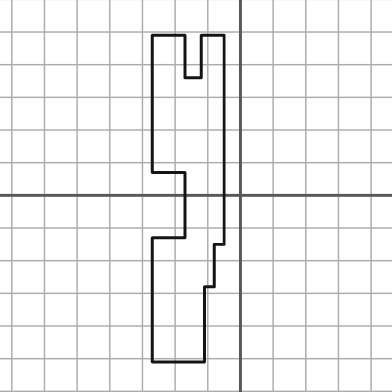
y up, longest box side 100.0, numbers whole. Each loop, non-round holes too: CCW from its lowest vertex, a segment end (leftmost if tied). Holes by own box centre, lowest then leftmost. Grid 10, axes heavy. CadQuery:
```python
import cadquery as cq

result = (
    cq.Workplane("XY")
    .moveTo(-27.0, -51.0)
    .lineTo(-11.0, -51.0)
    .lineTo(-11.0, -28.0)
    .lineTo(-8.0, -28.0)
    .lineTo(-8.0, -15.0)
    .lineTo(-5.0, -15.0)
    .lineTo(-5.0, 49.0)
    .lineTo(-12.0, 49.0)
    .lineTo(-12.0, 36.0)
    .lineTo(-17.0, 36.0)
    .lineTo(-17.0, 49.0)
    .lineTo(-27.0, 49.0)
    .lineTo(-27.0, 7.0)
    .lineTo(-17.0, 7.0)
    .lineTo(-17.0, -13.0)
    .lineTo(-27.0, -13.0)
    .close()
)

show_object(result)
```